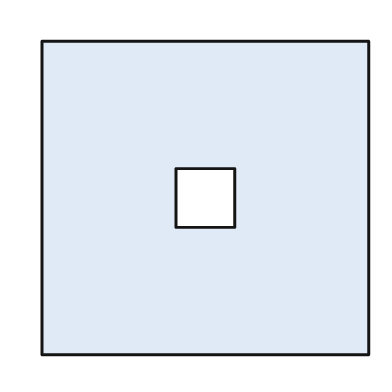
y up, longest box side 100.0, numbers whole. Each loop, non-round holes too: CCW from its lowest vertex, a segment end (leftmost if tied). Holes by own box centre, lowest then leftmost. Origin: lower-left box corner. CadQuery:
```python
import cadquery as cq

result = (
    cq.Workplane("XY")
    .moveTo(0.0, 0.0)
    .lineTo(100.0, 0.0)
    .lineTo(100.0, 96.0)
    .lineTo(0.0, 96.0)
    .close()
    .moveTo(41.0, 39.0)
    .lineTo(59.0, 39.0)
    .lineTo(59.0, 57.0)
    .lineTo(41.0, 57.0)
    .close()
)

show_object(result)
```